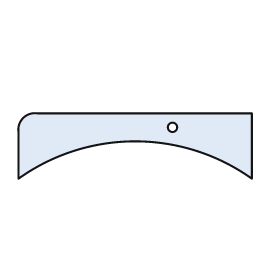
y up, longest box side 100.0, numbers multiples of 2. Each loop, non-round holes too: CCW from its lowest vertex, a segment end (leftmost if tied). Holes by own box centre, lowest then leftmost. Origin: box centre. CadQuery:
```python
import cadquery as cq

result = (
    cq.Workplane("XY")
    .moveTo(-50.0, -14.0)
    .threePointArc((0.0, 2.0), (50.0, -14.0))
    .lineTo(50.0, 14.0)
    .lineTo(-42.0, 14.0)
    .threePointArc((-48.0, 12.0), (-50.0, 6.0))
    .close()
    .moveTo(16.0, 8.0)
    .circle(2.0)
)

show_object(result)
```